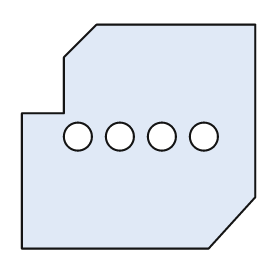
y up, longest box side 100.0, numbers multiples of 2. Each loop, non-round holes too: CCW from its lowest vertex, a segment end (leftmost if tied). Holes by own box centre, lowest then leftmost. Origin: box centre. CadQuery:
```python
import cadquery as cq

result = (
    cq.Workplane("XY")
    .moveTo(-50.0, -48.0)
    .lineTo(30.0, -48.0)
    .lineTo(50.0, -26.0)
    .lineTo(50.0, 48.0)
    .lineTo(-18.0, 48.0)
    .lineTo(-32.0, 34.0)
    .lineTo(-32.0, 10.0)
    .lineTo(-50.0, 10.0)
    .close()
    .moveTo(-26.0, 0.0)
    .circle(6.0)
    .moveTo(-8.0, 0.0)
    .circle(6.0)
    .moveTo(10.0, 0.0)
    .circle(6.0)
    .moveTo(28.0, 0.0)
    .circle(6.0)
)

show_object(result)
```